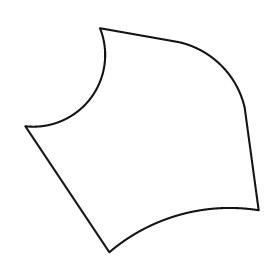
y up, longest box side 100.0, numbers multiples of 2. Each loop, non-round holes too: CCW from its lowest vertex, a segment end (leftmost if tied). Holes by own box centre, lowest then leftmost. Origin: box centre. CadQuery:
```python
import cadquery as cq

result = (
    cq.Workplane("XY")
    .moveTo(-14.0, -48.0)
    .threePointArc((16.0, -32.0), (50.0, -30.0))
    .lineTo(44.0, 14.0)
    .threePointArc((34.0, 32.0), (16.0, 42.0))
    .lineTo(-18.0, 48.0)
    .threePointArc((-22.0, 18.0), (-50.0, 6.0))
    .close()
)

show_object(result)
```